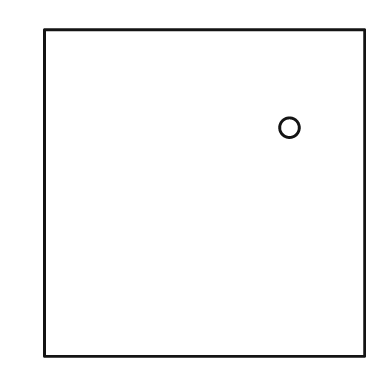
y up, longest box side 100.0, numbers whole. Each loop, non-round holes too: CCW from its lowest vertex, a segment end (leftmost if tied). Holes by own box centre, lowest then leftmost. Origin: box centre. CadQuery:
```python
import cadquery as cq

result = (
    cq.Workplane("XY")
    .moveTo(-49.0, -50.0)
    .lineTo(49.0, -50.0)
    .lineTo(49.0, 50.0)
    .lineTo(-49.0, 50.0)
    .close()
    .moveTo(26.0, 20.0)
    .circle(3.0)
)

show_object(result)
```